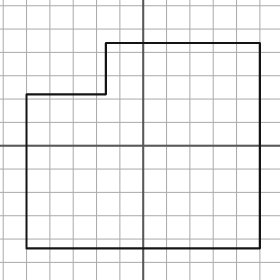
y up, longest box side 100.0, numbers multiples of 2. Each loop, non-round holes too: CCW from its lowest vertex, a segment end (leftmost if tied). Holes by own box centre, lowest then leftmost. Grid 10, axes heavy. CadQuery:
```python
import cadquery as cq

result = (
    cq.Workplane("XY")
    .moveTo(-50.0, -44.0)
    .lineTo(50.0, -44.0)
    .lineTo(50.0, 44.0)
    .lineTo(-16.0, 44.0)
    .lineTo(-16.0, 22.0)
    .lineTo(-50.0, 22.0)
    .close()
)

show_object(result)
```